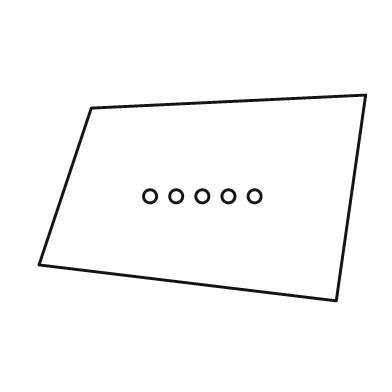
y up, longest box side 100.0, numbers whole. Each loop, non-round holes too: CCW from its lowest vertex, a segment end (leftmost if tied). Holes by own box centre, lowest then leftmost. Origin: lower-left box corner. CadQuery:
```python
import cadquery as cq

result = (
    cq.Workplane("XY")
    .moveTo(91.0, 0.0)
    .lineTo(100.0, 63.0)
    .lineTo(16.0, 59.0)
    .lineTo(0.0, 11.0)
    .close()
    .moveTo(34.0, 32.0)
    .circle(2.0)
    .moveTo(42.0, 32.0)
    .circle(2.0)
    .moveTo(50.0, 32.0)
    .circle(2.0)
    .moveTo(58.0, 32.0)
    .circle(2.0)
    .moveTo(66.0, 32.0)
    .circle(2.0)
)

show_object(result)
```